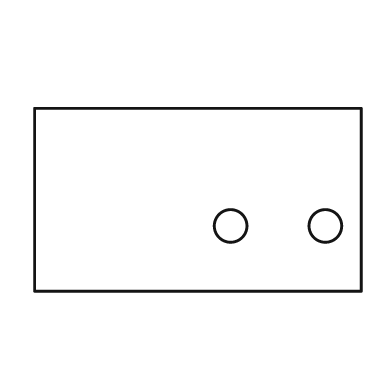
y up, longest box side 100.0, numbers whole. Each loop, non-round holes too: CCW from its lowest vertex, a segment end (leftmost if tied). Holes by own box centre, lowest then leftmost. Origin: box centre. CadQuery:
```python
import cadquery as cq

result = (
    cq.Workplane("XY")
    .moveTo(-50.0, -28.0)
    .lineTo(50.0, -28.0)
    .lineTo(50.0, 28.0)
    .lineTo(-50.0, 28.0)
    .close()
    .moveTo(10.0, -8.0)
    .circle(5.0)
    .moveTo(39.0, -8.0)
    .circle(5.0)
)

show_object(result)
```